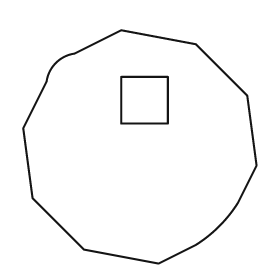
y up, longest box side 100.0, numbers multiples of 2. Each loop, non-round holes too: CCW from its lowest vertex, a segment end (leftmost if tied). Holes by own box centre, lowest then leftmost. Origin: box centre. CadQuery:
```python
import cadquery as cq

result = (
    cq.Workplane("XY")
    .moveTo(8.0, -50.0)
    .lineTo(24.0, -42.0)
    .threePointArc((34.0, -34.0), (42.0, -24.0))
    .lineTo(50.0, -8.0)
    .lineTo(46.0, 22.0)
    .lineTo(24.0, 44.0)
    .lineTo(-8.0, 50.0)
    .lineTo(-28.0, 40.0)
    .threePointArc((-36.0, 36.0), (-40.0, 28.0))
    .lineTo(-50.0, 8.0)
    .lineTo(-46.0, -22.0)
    .lineTo(-24.0, -44.0)
    .close()
    .moveTo(-8.0, 10.0)
    .lineTo(12.0, 10.0)
    .lineTo(12.0, 30.0)
    .lineTo(-8.0, 30.0)
    .close()
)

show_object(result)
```